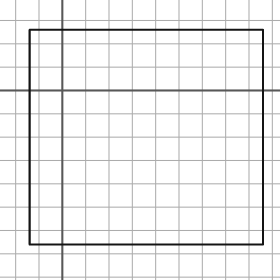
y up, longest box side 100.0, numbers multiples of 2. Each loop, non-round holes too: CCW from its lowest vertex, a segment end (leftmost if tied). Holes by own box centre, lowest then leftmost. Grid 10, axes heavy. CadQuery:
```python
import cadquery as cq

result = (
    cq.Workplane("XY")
    .moveTo(-14.0, -66.0)
    .lineTo(86.0, -66.0)
    .lineTo(86.0, 26.0)
    .lineTo(-14.0, 26.0)
    .close()
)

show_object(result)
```